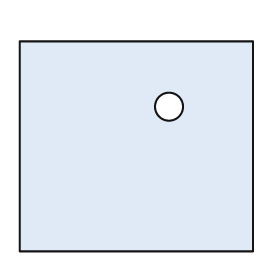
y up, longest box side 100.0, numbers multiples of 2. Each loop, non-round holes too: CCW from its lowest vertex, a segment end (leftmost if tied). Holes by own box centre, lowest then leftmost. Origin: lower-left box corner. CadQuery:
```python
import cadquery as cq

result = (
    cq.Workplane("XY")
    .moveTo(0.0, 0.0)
    .lineTo(100.0, 0.0)
    .lineTo(100.0, 90.0)
    .lineTo(0.0, 90.0)
    .close()
    .moveTo(64.0, 62.0)
    .circle(6.0)
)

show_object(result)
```